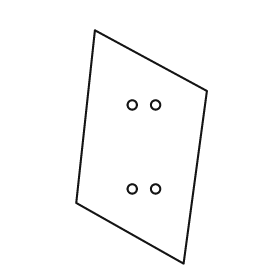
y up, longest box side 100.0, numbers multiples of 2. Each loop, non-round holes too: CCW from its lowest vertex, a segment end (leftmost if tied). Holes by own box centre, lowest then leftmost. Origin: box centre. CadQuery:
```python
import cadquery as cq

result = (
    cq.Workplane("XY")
    .moveTo(18.0, -50.0)
    .lineTo(28.0, 24.0)
    .lineTo(-20.0, 50.0)
    .lineTo(-28.0, -24.0)
    .close()
    .moveTo(-4.0, -18.0)
    .circle(2.0)
    .moveTo(6.0, -18.0)
    .circle(2.0)
    .moveTo(-4.0, 18.0)
    .circle(2.0)
    .moveTo(6.0, 18.0)
    .circle(2.0)
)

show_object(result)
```